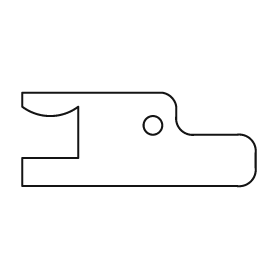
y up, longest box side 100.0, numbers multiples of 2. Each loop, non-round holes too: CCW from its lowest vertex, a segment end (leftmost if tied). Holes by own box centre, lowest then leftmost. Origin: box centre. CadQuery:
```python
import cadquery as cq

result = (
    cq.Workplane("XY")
    .moveTo(-50.0, -20.0)
    .lineTo(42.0, -20.0)
    .threePointArc((48.0, -18.0), (50.0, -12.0))
    .lineTo(50.0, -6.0)
    .threePointArc((48.0, 0.0), (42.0, 2.0))
    .lineTo(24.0, 2.0)
    .threePointArc((18.0, 4.0), (16.0, 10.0))
    .lineTo(16.0, 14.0)
    .threePointArc((14.0, 18.0), (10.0, 20.0))
    .lineTo(-50.0, 20.0)
    .lineTo(-50.0, 14.0)
    .threePointArc((-38.0, 10.0), (-26.0, 14.0))
    .lineTo(-26.0, -8.0)
    .lineTo(-50.0, -8.0)
    .close()
    .moveTo(6.0, 6.0)
    .circle(4.0)
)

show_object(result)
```